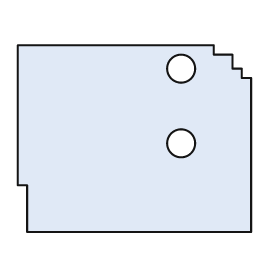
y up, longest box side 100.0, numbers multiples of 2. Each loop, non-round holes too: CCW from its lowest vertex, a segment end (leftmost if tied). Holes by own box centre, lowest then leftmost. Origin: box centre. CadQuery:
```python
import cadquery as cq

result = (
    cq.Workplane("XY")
    .moveTo(-46.0, -40.0)
    .lineTo(50.0, -40.0)
    .lineTo(50.0, 26.0)
    .lineTo(46.0, 26.0)
    .lineTo(46.0, 30.0)
    .lineTo(42.0, 30.0)
    .lineTo(42.0, 36.0)
    .lineTo(34.0, 36.0)
    .lineTo(34.0, 40.0)
    .lineTo(-50.0, 40.0)
    .lineTo(-50.0, -20.0)
    .lineTo(-46.0, -20.0)
    .close()
    .moveTo(20.0, -2.0)
    .circle(6.0)
    .moveTo(20.0, 30.0)
    .circle(6.0)
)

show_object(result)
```